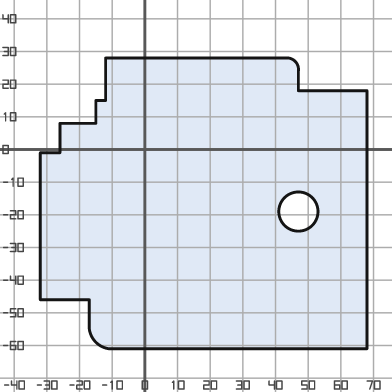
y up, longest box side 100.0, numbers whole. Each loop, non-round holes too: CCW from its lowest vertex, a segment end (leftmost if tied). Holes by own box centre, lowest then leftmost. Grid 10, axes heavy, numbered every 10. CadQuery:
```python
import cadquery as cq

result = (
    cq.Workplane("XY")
    .moveTo(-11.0, -61.0)
    .lineTo(68.0, -61.0)
    .lineTo(68.0, 18.0)
    .lineTo(47.0, 18.0)
    .lineTo(47.0, 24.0)
    .threePointArc((46.0, 27.0), (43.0, 28.0))
    .lineTo(-12.0, 28.0)
    .lineTo(-12.0, 15.0)
    .lineTo(-15.0, 15.0)
    .lineTo(-15.0, 8.0)
    .lineTo(-26.0, 8.0)
    .lineTo(-26.0, -1.0)
    .lineTo(-32.0, -1.0)
    .lineTo(-32.0, -46.0)
    .lineTo(-17.0, -46.0)
    .lineTo(-17.0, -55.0)
    .threePointArc((-15.0, -59.0), (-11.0, -61.0))
    .close()
    .moveTo(47.0, -19.0)
    .circle(6.0)
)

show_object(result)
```